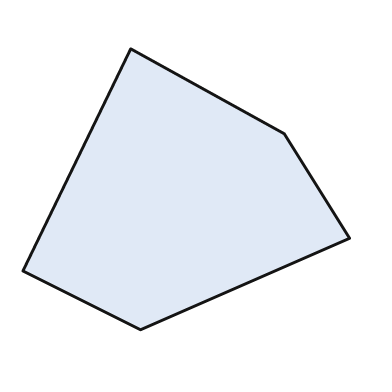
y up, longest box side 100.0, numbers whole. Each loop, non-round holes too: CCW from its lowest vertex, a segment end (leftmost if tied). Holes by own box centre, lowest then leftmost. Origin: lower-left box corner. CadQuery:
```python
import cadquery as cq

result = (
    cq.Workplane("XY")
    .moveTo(36.0, 0.0)
    .lineTo(100.0, 28.0)
    .lineTo(80.0, 60.0)
    .lineTo(33.0, 86.0)
    .lineTo(0.0, 18.0)
    .close()
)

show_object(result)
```